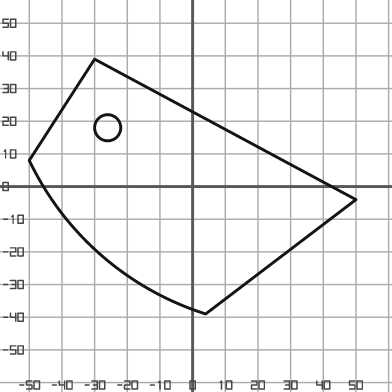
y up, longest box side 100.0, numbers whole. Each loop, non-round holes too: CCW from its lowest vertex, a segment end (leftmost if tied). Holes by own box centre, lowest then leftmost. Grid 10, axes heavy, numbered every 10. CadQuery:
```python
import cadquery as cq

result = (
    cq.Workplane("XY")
    .moveTo(4.0, -39.0)
    .lineTo(50.0, -4.0)
    .lineTo(-30.0, 39.0)
    .lineTo(-50.0, 8.0)
    .threePointArc((-28.0, -21.0), (4.0, -39.0))
    .close()
    .moveTo(-26.0, 18.0)
    .circle(4.0)
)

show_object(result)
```